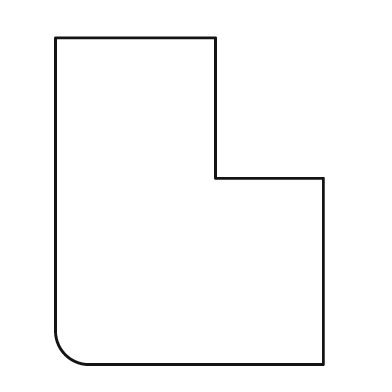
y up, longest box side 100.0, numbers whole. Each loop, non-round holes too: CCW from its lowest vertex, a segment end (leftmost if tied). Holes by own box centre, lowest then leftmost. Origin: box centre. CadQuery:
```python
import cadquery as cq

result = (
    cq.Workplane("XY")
    .moveTo(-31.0, -50.0)
    .lineTo(41.0, -50.0)
    .lineTo(41.0, 7.0)
    .lineTo(8.0, 7.0)
    .lineTo(8.0, 50.0)
    .lineTo(-41.0, 50.0)
    .lineTo(-41.0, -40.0)
    .threePointArc((-38.0, -47.0), (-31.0, -50.0))
    .close()
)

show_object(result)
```